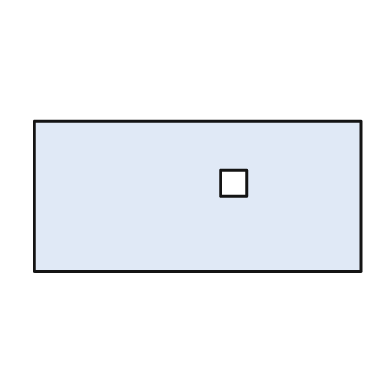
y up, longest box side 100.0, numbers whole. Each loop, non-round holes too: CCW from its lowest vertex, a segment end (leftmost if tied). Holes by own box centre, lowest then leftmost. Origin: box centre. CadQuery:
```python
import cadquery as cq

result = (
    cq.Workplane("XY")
    .moveTo(-50.0, -23.0)
    .lineTo(50.0, -23.0)
    .lineTo(50.0, 23.0)
    .lineTo(-50.0, 23.0)
    .close()
    .moveTo(7.0, 0.0)
    .lineTo(15.0, 0.0)
    .lineTo(15.0, 8.0)
    .lineTo(7.0, 8.0)
    .close()
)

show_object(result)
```